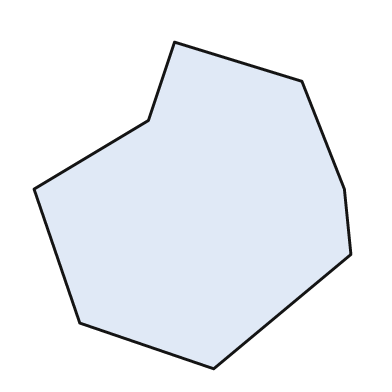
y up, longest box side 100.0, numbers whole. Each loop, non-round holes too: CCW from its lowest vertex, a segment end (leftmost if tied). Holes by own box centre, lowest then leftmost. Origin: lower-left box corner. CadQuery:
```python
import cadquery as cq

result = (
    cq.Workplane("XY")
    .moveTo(55.0, 0.0)
    .lineTo(97.0, 35.0)
    .lineTo(95.0, 55.0)
    .lineTo(82.0, 88.0)
    .lineTo(43.0, 100.0)
    .lineTo(35.0, 76.0)
    .lineTo(0.0, 55.0)
    .lineTo(14.0, 14.0)
    .close()
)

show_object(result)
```